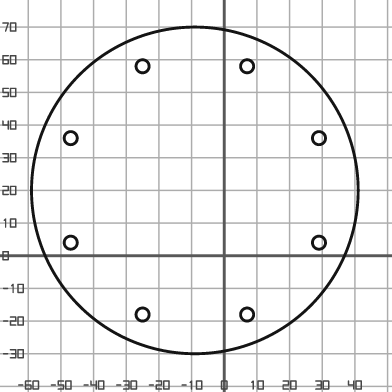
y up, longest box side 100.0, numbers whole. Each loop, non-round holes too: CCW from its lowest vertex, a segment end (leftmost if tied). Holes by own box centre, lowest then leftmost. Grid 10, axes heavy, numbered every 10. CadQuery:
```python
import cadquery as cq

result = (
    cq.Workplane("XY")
    .moveTo(-9.0, 20.0)
    .circle(50.0)
    .moveTo(-25.0, -18.0)
    .circle(2.0)
    .moveTo(7.0, -18.0)
    .circle(2.0)
    .moveTo(-47.0, 4.0)
    .circle(2.0)
    .moveTo(29.0, 4.0)
    .circle(2.0)
    .moveTo(-47.0, 36.0)
    .circle(2.0)
    .moveTo(29.0, 36.0)
    .circle(2.0)
    .moveTo(-25.0, 58.0)
    .circle(2.0)
    .moveTo(7.0, 58.0)
    .circle(2.0)
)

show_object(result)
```